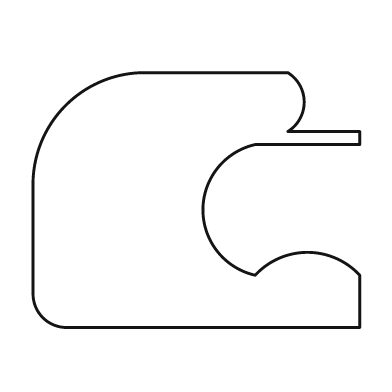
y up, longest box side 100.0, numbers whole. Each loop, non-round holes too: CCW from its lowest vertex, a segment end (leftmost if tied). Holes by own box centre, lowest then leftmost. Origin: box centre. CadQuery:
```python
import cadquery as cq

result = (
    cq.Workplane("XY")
    .moveTo(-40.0, -39.0)
    .lineTo(50.0, -39.0)
    .lineTo(50.0, -23.0)
    .threePointArc((34.0, -16.0), (18.0, -23.0))
    .threePointArc((2.0, -3.0), (18.0, 17.0))
    .lineTo(50.0, 17.0)
    .lineTo(50.0, 21.0)
    .lineTo(28.0, 21.0)
    .threePointArc((33.0, 30.0), (28.0, 39.0))
    .lineTo(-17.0, 39.0)
    .threePointArc((-40.0, 29.0), (-50.0, 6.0))
    .lineTo(-50.0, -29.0)
    .threePointArc((-47.0, -36.0), (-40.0, -39.0))
    .close()
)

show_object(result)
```